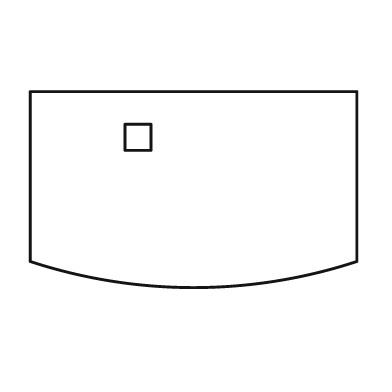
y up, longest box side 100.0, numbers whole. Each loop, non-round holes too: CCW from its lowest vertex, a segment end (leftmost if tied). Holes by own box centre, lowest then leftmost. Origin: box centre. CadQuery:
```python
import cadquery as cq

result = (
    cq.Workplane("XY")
    .moveTo(-50.0, -22.0)
    .threePointArc((0.0, -30.0), (50.0, -22.0))
    .lineTo(50.0, 30.0)
    .lineTo(-50.0, 30.0)
    .close()
    .moveTo(-21.0, 12.0)
    .lineTo(-13.0, 12.0)
    .lineTo(-13.0, 20.0)
    .lineTo(-21.0, 20.0)
    .close()
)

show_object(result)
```